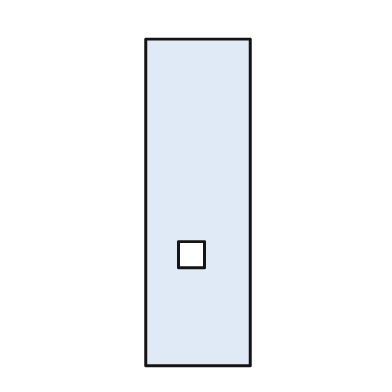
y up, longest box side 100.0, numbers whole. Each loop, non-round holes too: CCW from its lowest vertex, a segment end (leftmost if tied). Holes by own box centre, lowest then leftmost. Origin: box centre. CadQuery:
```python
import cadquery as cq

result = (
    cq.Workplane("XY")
    .moveTo(-16.0, -50.0)
    .lineTo(16.0, -50.0)
    .lineTo(16.0, 50.0)
    .lineTo(-16.0, 50.0)
    .close()
    .moveTo(-6.0, -20.0)
    .lineTo(2.0, -20.0)
    .lineTo(2.0, -12.0)
    .lineTo(-6.0, -12.0)
    .close()
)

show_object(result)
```